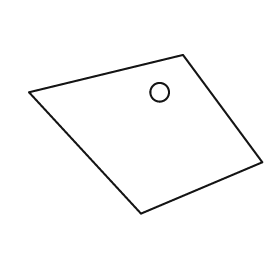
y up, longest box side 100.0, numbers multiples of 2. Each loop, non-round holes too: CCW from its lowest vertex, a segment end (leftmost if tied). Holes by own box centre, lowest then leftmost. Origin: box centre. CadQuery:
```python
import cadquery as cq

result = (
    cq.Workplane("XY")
    .moveTo(-2.0, -34.0)
    .lineTo(50.0, -12.0)
    .lineTo(16.0, 34.0)
    .lineTo(-50.0, 18.0)
    .close()
    .moveTo(6.0, 18.0)
    .circle(4.0)
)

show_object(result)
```